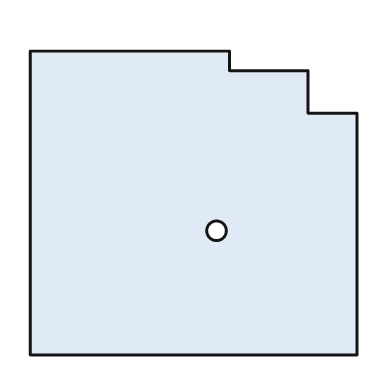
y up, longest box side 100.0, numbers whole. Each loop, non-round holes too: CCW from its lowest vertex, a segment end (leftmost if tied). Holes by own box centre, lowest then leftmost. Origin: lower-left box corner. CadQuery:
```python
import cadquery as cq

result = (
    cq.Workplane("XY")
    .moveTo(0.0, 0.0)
    .lineTo(100.0, 0.0)
    .lineTo(100.0, 74.0)
    .lineTo(85.0, 74.0)
    .lineTo(85.0, 87.0)
    .lineTo(61.0, 87.0)
    .lineTo(61.0, 93.0)
    .lineTo(0.0, 93.0)
    .close()
    .moveTo(57.0, 38.0)
    .circle(3.0)
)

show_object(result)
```